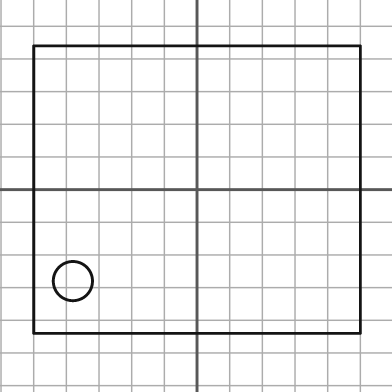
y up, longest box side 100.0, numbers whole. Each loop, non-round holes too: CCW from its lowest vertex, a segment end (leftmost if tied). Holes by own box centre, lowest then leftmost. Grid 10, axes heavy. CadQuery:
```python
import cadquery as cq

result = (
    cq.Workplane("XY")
    .moveTo(-50.0, -44.0)
    .lineTo(50.0, -44.0)
    .lineTo(50.0, 44.0)
    .lineTo(-50.0, 44.0)
    .close()
    .moveTo(-38.0, -28.0)
    .circle(6.0)
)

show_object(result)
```